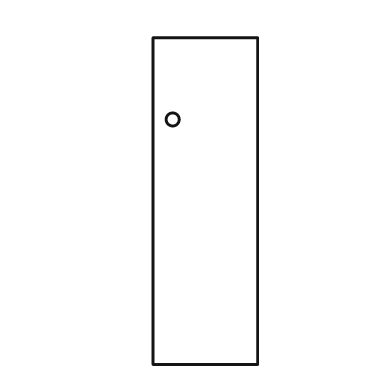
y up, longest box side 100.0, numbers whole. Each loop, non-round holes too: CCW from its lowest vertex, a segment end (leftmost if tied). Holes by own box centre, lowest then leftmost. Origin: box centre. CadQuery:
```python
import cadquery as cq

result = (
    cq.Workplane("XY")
    .moveTo(-16.0, -50.0)
    .lineTo(16.0, -50.0)
    .lineTo(16.0, 50.0)
    .lineTo(-16.0, 50.0)
    .close()
    .moveTo(-10.0, 25.0)
    .circle(2.0)
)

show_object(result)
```